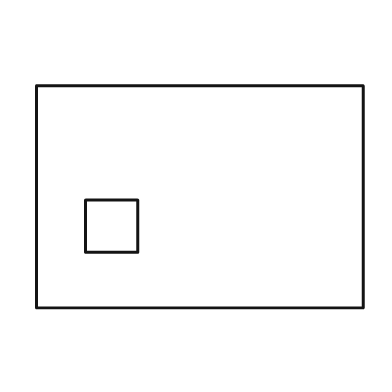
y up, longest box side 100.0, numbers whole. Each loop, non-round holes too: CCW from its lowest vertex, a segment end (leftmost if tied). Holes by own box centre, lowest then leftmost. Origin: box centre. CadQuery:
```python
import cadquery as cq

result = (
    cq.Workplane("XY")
    .moveTo(-50.0, -34.0)
    .lineTo(50.0, -34.0)
    .lineTo(50.0, 34.0)
    .lineTo(-50.0, 34.0)
    .close()
    .moveTo(-35.0, -17.0)
    .lineTo(-19.0, -17.0)
    .lineTo(-19.0, -1.0)
    .lineTo(-35.0, -1.0)
    .close()
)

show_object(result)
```